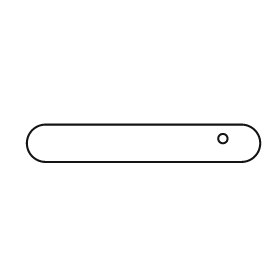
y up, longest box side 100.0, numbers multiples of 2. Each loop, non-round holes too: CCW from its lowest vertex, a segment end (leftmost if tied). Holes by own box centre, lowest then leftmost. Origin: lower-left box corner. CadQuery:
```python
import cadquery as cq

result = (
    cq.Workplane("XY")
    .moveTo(8.0, 0.0)
    .lineTo(92.0, 0.0)
    .threePointArc((100.0, 8.0), (92.0, 16.0))
    .lineTo(8.0, 16.0)
    .threePointArc((0.0, 8.0), (8.0, 0.0))
    .close()
    .moveTo(84.0, 10.0)
    .circle(2.0)
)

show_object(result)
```